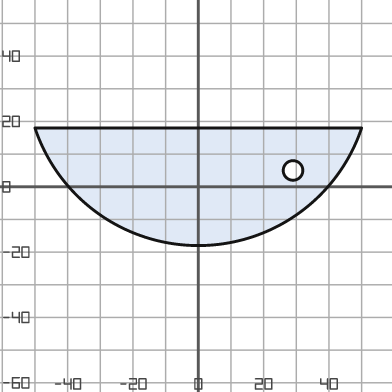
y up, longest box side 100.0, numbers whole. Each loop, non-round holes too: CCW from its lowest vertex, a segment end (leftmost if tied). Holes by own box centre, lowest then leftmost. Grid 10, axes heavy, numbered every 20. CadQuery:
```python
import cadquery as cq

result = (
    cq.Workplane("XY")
    .moveTo(-50.0, 18.0)
    .threePointArc((0.0, -18.0), (50.0, 18.0))
    .close()
    .moveTo(29.0, 5.0)
    .circle(3.0)
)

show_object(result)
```